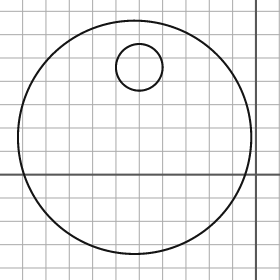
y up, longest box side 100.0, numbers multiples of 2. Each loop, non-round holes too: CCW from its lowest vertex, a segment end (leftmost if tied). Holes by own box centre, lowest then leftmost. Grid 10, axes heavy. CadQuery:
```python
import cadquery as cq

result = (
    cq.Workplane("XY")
    .moveTo(-52.0, 16.0)
    .circle(50.0)
    .moveTo(-50.0, 46.0)
    .circle(10.0)
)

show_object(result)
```